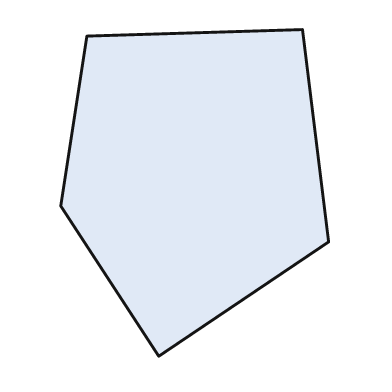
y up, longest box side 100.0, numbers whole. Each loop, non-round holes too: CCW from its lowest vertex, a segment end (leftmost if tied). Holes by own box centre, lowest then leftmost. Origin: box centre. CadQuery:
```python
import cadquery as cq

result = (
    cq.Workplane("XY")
    .moveTo(-11.0, -50.0)
    .lineTo(41.0, -15.0)
    .lineTo(33.0, 50.0)
    .lineTo(-33.0, 48.0)
    .lineTo(-41.0, -4.0)
    .close()
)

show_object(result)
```